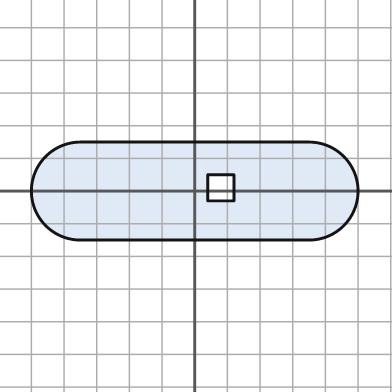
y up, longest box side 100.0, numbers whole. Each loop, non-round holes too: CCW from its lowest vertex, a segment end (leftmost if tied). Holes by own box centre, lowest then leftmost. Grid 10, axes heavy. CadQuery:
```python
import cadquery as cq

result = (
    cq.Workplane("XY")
    .moveTo(-35.0, -15.0)
    .lineTo(35.0, -15.0)
    .threePointArc((50.0, 0.0), (35.0, 15.0))
    .lineTo(-35.0, 15.0)
    .threePointArc((-50.0, 0.0), (-35.0, -15.0))
    .close()
    .moveTo(4.0, -3.0)
    .lineTo(12.0, -3.0)
    .lineTo(12.0, 5.0)
    .lineTo(4.0, 5.0)
    .close()
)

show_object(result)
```